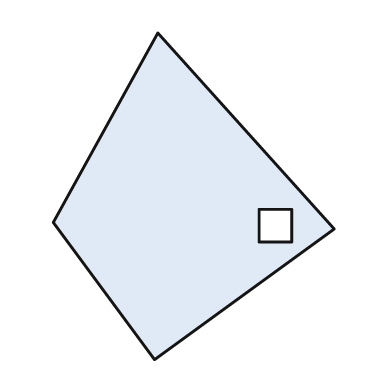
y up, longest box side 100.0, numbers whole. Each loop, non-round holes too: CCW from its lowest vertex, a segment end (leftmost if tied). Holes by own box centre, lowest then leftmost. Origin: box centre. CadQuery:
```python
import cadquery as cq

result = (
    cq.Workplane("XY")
    .moveTo(-12.0, -50.0)
    .lineTo(43.0, -10.0)
    .lineTo(-11.0, 50.0)
    .lineTo(-43.0, -8.0)
    .close()
    .moveTo(20.0, -14.0)
    .lineTo(30.0, -14.0)
    .lineTo(30.0, -4.0)
    .lineTo(20.0, -4.0)
    .close()
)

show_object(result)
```